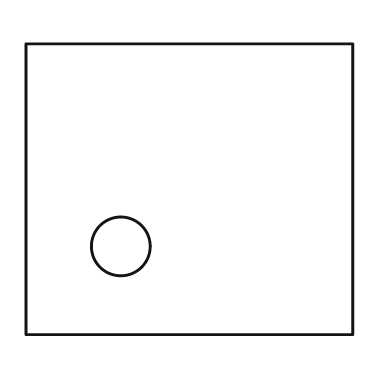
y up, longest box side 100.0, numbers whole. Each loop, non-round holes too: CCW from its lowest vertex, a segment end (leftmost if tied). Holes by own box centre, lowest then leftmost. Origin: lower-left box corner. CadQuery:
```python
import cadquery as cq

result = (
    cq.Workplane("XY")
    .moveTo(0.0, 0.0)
    .lineTo(100.0, 0.0)
    .lineTo(100.0, 89.0)
    .lineTo(0.0, 89.0)
    .close()
    .moveTo(29.0, 27.0)
    .circle(9.0)
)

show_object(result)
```